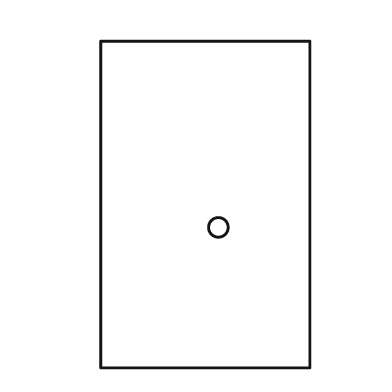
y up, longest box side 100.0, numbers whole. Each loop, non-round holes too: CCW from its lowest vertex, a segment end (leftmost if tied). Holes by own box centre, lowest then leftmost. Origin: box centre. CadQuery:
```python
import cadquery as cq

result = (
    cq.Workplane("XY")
    .moveTo(-32.0, -50.0)
    .lineTo(32.0, -50.0)
    .lineTo(32.0, 50.0)
    .lineTo(-32.0, 50.0)
    .close()
    .moveTo(4.0, -7.0)
    .circle(3.0)
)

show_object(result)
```